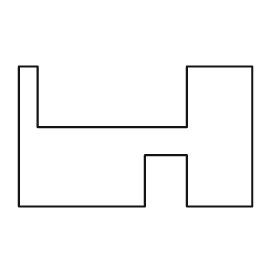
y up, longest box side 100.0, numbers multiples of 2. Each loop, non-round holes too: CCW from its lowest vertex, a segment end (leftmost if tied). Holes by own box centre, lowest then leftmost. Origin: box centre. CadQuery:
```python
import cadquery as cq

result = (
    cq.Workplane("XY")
    .moveTo(-50.0, -30.0)
    .lineTo(4.0, -30.0)
    .lineTo(4.0, -8.0)
    .lineTo(22.0, -8.0)
    .lineTo(22.0, -30.0)
    .lineTo(50.0, -30.0)
    .lineTo(50.0, 30.0)
    .lineTo(22.0, 30.0)
    .lineTo(22.0, 4.0)
    .lineTo(-42.0, 4.0)
    .lineTo(-42.0, 30.0)
    .lineTo(-50.0, 30.0)
    .close()
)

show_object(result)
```